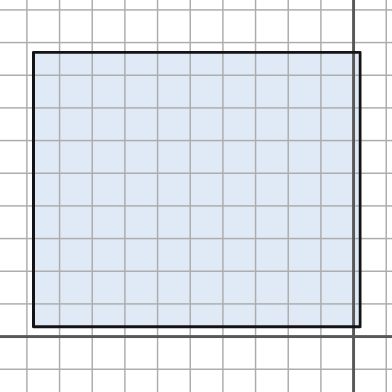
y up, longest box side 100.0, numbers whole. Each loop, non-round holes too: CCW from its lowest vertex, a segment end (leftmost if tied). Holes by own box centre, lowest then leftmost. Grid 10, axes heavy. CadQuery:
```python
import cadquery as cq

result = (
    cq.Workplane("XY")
    .moveTo(-98.0, 3.0)
    .lineTo(2.0, 3.0)
    .lineTo(2.0, 87.0)
    .lineTo(-98.0, 87.0)
    .close()
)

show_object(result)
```